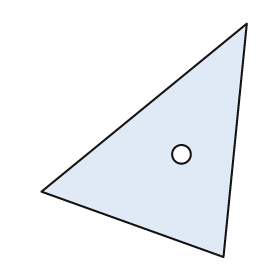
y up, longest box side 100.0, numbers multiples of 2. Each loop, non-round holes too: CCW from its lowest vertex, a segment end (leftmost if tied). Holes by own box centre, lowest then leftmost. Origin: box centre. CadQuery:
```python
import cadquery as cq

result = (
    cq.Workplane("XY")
    .moveTo(34.0, -50.0)
    .lineTo(44.0, 50.0)
    .lineTo(-44.0, -22.0)
    .close()
    .moveTo(16.0, -6.0)
    .circle(4.0)
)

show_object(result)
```